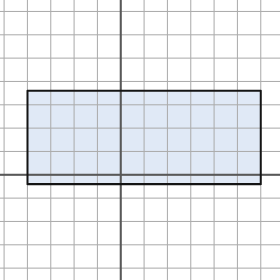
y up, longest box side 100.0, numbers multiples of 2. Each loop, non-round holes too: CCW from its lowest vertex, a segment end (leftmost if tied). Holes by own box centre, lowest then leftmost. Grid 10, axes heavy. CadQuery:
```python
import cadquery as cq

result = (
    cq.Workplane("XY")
    .moveTo(-40.0, -4.0)
    .lineTo(60.0, -4.0)
    .lineTo(60.0, 36.0)
    .lineTo(-40.0, 36.0)
    .close()
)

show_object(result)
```